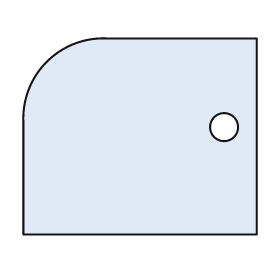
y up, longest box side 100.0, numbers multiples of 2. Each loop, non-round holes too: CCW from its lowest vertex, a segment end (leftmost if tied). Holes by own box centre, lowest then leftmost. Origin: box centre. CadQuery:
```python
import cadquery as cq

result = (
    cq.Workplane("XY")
    .moveTo(-50.0, -42.0)
    .lineTo(50.0, -42.0)
    .lineTo(50.0, 42.0)
    .lineTo(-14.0, 42.0)
    .threePointArc((-40.0, 32.0), (-50.0, 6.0))
    .close()
    .moveTo(36.0, 4.0)
    .circle(6.0)
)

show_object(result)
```